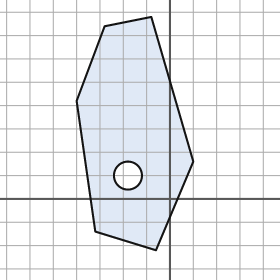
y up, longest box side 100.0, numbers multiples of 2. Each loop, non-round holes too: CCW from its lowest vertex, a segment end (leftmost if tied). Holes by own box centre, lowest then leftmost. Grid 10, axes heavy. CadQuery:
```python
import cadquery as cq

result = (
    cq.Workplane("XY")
    .moveTo(-6.0, -22.0)
    .lineTo(10.0, 16.0)
    .lineTo(-8.0, 78.0)
    .lineTo(-28.0, 74.0)
    .lineTo(-40.0, 42.0)
    .lineTo(-32.0, -14.0)
    .close()
    .moveTo(-18.0, 10.0)
    .circle(6.0)
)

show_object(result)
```